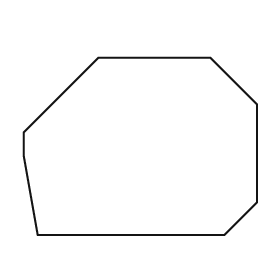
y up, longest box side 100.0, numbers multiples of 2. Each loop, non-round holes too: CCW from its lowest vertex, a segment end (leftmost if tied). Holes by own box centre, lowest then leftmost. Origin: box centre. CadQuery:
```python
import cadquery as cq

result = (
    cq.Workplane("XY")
    .moveTo(-44.0, -38.0)
    .lineTo(36.0, -38.0)
    .lineTo(50.0, -24.0)
    .lineTo(50.0, 18.0)
    .lineTo(30.0, 38.0)
    .lineTo(-18.0, 38.0)
    .lineTo(-50.0, 6.0)
    .lineTo(-50.0, -4.0)
    .close()
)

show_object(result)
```